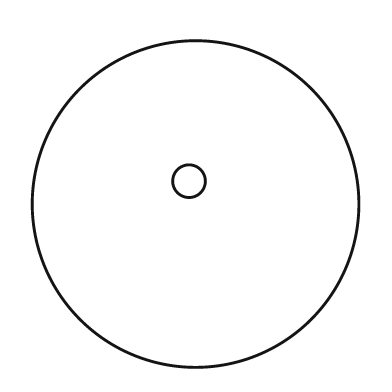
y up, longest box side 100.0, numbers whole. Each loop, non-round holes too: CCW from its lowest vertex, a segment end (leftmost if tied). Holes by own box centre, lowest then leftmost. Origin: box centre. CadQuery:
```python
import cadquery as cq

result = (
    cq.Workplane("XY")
    .moveTo(0.0, 0.0)
    .circle(50.0)
    .moveTo(-2.0, 7.0)
    .circle(5.0)
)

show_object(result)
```